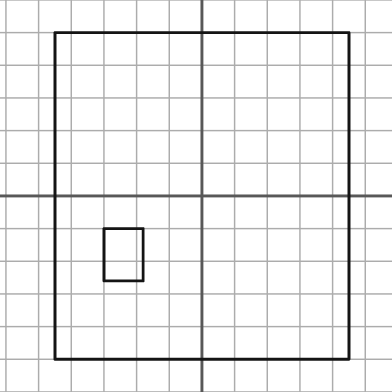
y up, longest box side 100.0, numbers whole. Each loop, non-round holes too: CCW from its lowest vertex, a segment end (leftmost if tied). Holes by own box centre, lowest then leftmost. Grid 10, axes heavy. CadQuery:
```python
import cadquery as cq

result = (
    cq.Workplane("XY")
    .moveTo(-45.0, -50.0)
    .lineTo(45.0, -50.0)
    .lineTo(45.0, 50.0)
    .lineTo(-45.0, 50.0)
    .close()
    .moveTo(-30.0, -26.0)
    .lineTo(-18.0, -26.0)
    .lineTo(-18.0, -10.0)
    .lineTo(-30.0, -10.0)
    .close()
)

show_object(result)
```